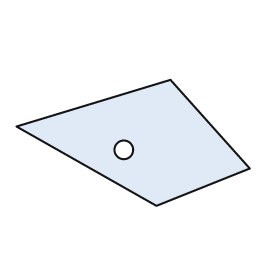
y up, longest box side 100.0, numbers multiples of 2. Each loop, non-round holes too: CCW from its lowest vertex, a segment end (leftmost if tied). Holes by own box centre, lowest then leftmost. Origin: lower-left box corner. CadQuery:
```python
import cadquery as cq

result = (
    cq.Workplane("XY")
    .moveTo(60.0, 0.0)
    .lineTo(100.0, 16.0)
    .lineTo(66.0, 54.0)
    .lineTo(0.0, 34.0)
    .close()
    .moveTo(46.0, 24.0)
    .circle(4.0)
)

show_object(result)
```